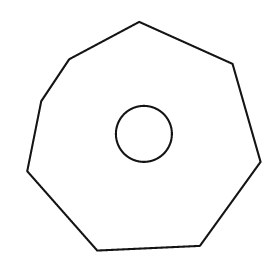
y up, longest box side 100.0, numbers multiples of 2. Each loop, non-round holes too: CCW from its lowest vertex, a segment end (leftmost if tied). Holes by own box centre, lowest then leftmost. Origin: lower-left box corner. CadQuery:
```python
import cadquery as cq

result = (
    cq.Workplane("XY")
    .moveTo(30.0, 0.0)
    .lineTo(74.0, 2.0)
    .lineTo(100.0, 38.0)
    .lineTo(88.0, 80.0)
    .lineTo(48.0, 98.0)
    .lineTo(18.0, 82.0)
    .lineTo(6.0, 64.0)
    .lineTo(0.0, 34.0)
    .close()
    .moveTo(50.0, 50.0)
    .circle(12.0)
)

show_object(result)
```